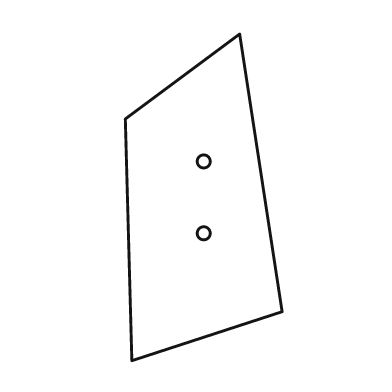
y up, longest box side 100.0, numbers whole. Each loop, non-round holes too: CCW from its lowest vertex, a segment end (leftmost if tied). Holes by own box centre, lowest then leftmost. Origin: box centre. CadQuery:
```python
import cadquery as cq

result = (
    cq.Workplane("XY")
    .moveTo(-22.0, -50.0)
    .lineTo(24.0, -35.0)
    .lineTo(11.0, 50.0)
    .lineTo(-24.0, 24.0)
    .close()
    .moveTo(0.0, -11.0)
    .circle(2.0)
    .moveTo(0.0, 11.0)
    .circle(2.0)
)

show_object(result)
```